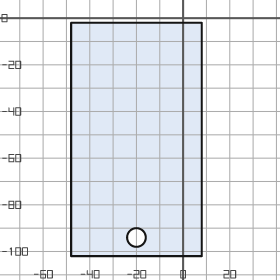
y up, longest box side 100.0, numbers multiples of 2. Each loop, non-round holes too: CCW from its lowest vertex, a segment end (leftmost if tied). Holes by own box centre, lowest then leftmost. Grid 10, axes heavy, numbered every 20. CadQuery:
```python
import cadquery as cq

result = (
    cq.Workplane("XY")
    .moveTo(-48.0, -102.0)
    .lineTo(8.0, -102.0)
    .lineTo(8.0, -2.0)
    .lineTo(-48.0, -2.0)
    .close()
    .moveTo(-20.0, -94.0)
    .circle(4.0)
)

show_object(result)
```